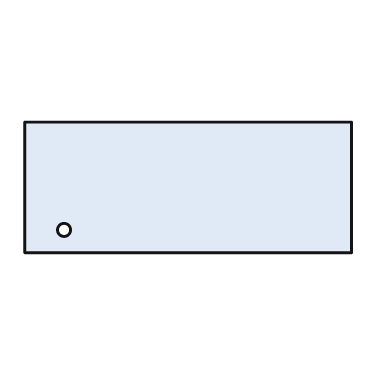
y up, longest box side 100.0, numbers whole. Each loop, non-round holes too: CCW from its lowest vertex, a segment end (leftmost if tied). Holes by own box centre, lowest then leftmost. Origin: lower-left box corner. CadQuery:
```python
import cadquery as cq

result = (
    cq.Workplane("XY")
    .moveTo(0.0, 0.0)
    .lineTo(100.0, 0.0)
    .lineTo(100.0, 40.0)
    .lineTo(0.0, 40.0)
    .close()
    .moveTo(12.0, 7.0)
    .circle(2.0)
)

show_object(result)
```